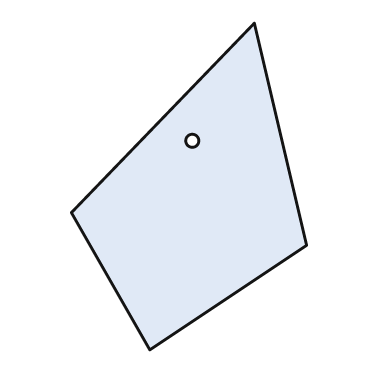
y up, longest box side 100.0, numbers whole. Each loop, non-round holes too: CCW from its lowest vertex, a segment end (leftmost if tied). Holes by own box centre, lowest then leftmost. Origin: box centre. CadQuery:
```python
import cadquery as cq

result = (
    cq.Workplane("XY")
    .moveTo(-12.0, -50.0)
    .lineTo(36.0, -18.0)
    .lineTo(20.0, 50.0)
    .lineTo(-36.0, -8.0)
    .close()
    .moveTo(1.0, 14.0)
    .circle(2.0)
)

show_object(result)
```